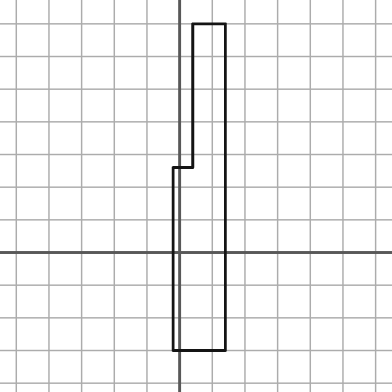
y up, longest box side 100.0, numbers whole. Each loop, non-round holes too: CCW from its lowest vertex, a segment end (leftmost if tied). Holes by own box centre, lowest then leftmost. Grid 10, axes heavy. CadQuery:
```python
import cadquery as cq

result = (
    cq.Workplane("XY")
    .moveTo(-2.0, -30.0)
    .lineTo(14.0, -30.0)
    .lineTo(14.0, 70.0)
    .lineTo(4.0, 70.0)
    .lineTo(4.0, 26.0)
    .lineTo(-2.0, 26.0)
    .close()
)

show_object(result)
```